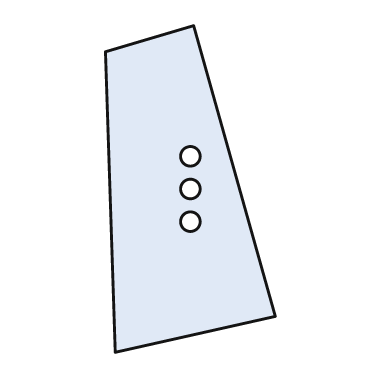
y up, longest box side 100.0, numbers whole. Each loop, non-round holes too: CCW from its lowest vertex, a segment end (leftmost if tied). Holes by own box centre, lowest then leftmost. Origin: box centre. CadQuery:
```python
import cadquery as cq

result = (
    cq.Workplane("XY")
    .moveTo(-23.0, -50.0)
    .lineTo(26.0, -39.0)
    .lineTo(1.0, 50.0)
    .lineTo(-26.0, 42.0)
    .close()
    .moveTo(0.0, -10.0)
    .circle(3.0)
    .moveTo(0.0, 0.0)
    .circle(3.0)
    .moveTo(0.0, 10.0)
    .circle(3.0)
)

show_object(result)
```